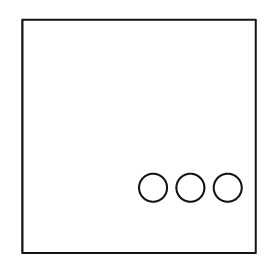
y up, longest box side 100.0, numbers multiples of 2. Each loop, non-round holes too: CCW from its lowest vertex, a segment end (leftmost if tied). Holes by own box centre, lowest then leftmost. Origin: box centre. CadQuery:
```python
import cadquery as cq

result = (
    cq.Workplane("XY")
    .moveTo(-50.0, -50.0)
    .lineTo(50.0, -50.0)
    .lineTo(50.0, 50.0)
    .lineTo(-50.0, 50.0)
    .close()
    .moveTo(6.0, -22.0)
    .circle(6.0)
    .moveTo(22.0, -22.0)
    .circle(6.0)
    .moveTo(38.0, -22.0)
    .circle(6.0)
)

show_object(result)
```